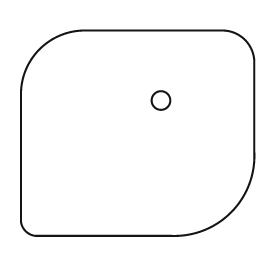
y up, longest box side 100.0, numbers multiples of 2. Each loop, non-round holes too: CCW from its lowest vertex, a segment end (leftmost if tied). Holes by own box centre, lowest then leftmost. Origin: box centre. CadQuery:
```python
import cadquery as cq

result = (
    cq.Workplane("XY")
    .moveTo(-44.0, -44.0)
    .lineTo(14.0, -44.0)
    .threePointArc((40.0, -34.0), (50.0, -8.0))
    .lineTo(50.0, 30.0)
    .threePointArc((46.0, 40.0), (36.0, 44.0))
    .lineTo(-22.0, 44.0)
    .threePointArc((-42.0, 36.0), (-50.0, 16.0))
    .lineTo(-50.0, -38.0)
    .threePointArc((-48.0, -42.0), (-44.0, -44.0))
    .close()
    .moveTo(10.0, 14.0)
    .circle(4.0)
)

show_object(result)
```